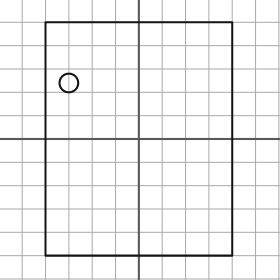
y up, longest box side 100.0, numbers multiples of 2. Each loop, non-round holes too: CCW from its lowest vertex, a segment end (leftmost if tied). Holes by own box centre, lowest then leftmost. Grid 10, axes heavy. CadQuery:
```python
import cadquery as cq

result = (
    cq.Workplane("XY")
    .moveTo(-40.0, -50.0)
    .lineTo(40.0, -50.0)
    .lineTo(40.0, 50.0)
    .lineTo(-40.0, 50.0)
    .close()
    .moveTo(-30.0, 24.0)
    .circle(4.0)
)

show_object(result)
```